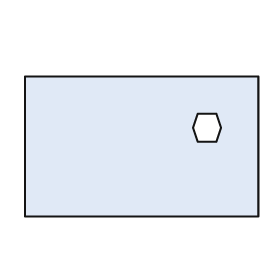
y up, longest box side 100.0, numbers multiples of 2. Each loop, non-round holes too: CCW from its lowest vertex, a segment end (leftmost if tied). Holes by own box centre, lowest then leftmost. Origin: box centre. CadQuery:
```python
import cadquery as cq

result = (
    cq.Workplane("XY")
    .moveTo(-50.0, -30.0)
    .lineTo(50.0, -30.0)
    .lineTo(50.0, 30.0)
    .lineTo(-50.0, 30.0)
    .close()
    .moveTo(24.0, 2.0)
    .lineTo(32.0, 2.0)
    .lineTo(34.0, 8.0)
    .lineTo(32.0, 14.0)
    .lineTo(24.0, 14.0)
    .lineTo(22.0, 8.0)
    .close()
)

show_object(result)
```